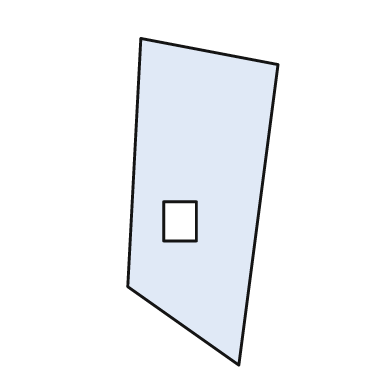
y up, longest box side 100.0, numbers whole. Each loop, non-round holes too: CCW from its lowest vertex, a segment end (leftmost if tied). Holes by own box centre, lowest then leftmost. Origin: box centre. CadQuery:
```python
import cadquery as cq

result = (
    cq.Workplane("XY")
    .moveTo(11.0, -50.0)
    .lineTo(23.0, 42.0)
    .lineTo(-19.0, 50.0)
    .lineTo(-23.0, -26.0)
    .close()
    .moveTo(-12.0, -12.0)
    .lineTo(-2.0, -12.0)
    .lineTo(-2.0, 0.0)
    .lineTo(-12.0, 0.0)
    .close()
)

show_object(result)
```